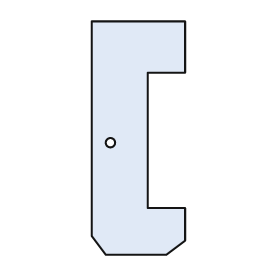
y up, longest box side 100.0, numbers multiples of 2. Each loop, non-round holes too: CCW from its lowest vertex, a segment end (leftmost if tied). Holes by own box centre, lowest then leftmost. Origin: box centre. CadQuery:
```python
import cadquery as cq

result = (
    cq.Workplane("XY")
    .moveTo(-14.0, -50.0)
    .lineTo(12.0, -50.0)
    .lineTo(20.0, -44.0)
    .lineTo(20.0, -30.0)
    .lineTo(4.0, -30.0)
    .lineTo(4.0, 28.0)
    .lineTo(20.0, 28.0)
    .lineTo(20.0, 50.0)
    .lineTo(-20.0, 50.0)
    .lineTo(-20.0, -42.0)
    .close()
    .moveTo(-12.0, -2.0)
    .circle(2.0)
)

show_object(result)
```